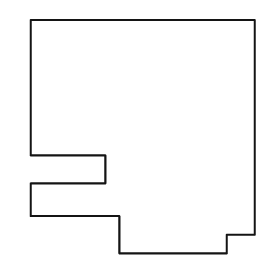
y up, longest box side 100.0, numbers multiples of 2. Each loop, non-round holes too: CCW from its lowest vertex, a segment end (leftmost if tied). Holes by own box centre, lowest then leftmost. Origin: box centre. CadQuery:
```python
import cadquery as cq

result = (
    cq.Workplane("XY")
    .moveTo(-10.0, -50.0)
    .lineTo(36.0, -50.0)
    .lineTo(36.0, -42.0)
    .lineTo(48.0, -42.0)
    .lineTo(48.0, 50.0)
    .lineTo(-48.0, 50.0)
    .lineTo(-48.0, -8.0)
    .lineTo(-16.0, -8.0)
    .lineTo(-16.0, -20.0)
    .lineTo(-48.0, -20.0)
    .lineTo(-48.0, -34.0)
    .lineTo(-10.0, -34.0)
    .close()
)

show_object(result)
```